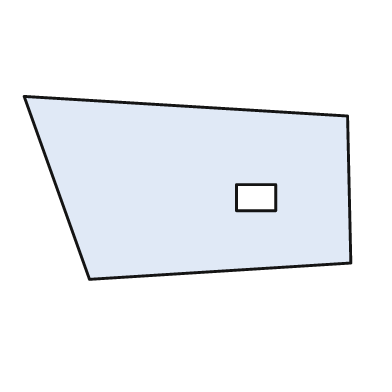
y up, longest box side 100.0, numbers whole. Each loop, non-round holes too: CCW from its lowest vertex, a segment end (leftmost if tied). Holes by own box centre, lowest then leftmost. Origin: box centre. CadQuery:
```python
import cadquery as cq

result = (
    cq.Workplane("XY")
    .moveTo(-30.0, -28.0)
    .lineTo(50.0, -23.0)
    .lineTo(49.0, 22.0)
    .lineTo(-50.0, 28.0)
    .close()
    .moveTo(15.0, -7.0)
    .lineTo(27.0, -7.0)
    .lineTo(27.0, 1.0)
    .lineTo(15.0, 1.0)
    .close()
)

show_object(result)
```